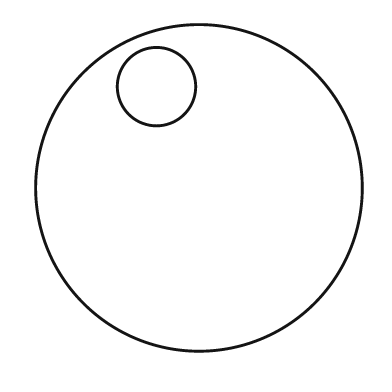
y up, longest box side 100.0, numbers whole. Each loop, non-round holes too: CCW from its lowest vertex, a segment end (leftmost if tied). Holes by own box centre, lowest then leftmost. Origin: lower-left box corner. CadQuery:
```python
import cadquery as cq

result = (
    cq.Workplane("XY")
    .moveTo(50.0, 50.0)
    .circle(50.0)
    .moveTo(37.0, 81.0)
    .circle(12.0)
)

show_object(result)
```